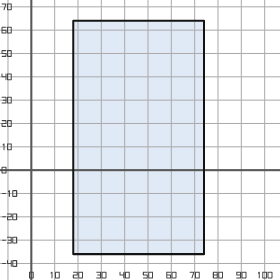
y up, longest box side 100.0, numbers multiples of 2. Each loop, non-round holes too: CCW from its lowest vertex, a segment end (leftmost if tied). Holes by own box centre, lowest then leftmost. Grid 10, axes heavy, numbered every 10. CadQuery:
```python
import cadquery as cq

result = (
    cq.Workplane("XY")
    .moveTo(18.0, -36.0)
    .lineTo(74.0, -36.0)
    .lineTo(74.0, 64.0)
    .lineTo(18.0, 64.0)
    .close()
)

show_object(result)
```